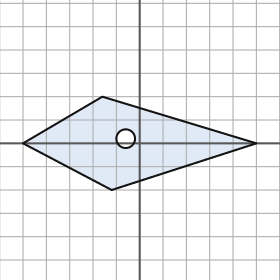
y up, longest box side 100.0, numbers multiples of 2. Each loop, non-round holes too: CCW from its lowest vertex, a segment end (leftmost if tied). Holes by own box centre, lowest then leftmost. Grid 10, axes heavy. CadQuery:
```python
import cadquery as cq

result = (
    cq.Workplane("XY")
    .moveTo(-12.0, -20.0)
    .lineTo(50.0, 0.0)
    .lineTo(-16.0, 20.0)
    .lineTo(-50.0, 0.0)
    .close()
    .moveTo(-6.0, 2.0)
    .circle(4.0)
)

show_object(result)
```